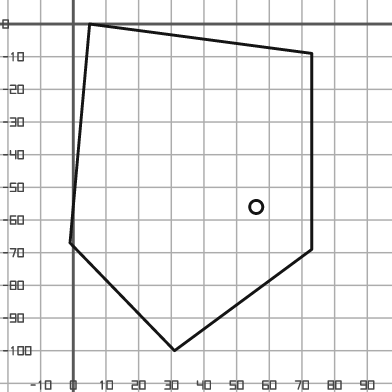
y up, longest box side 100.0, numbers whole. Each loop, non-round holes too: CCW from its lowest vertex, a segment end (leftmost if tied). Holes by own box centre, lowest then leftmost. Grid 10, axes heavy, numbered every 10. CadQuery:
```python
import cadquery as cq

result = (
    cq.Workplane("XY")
    .moveTo(31.0, -100.0)
    .lineTo(73.0, -69.0)
    .lineTo(73.0, -9.0)
    .lineTo(5.0, 0.0)
    .lineTo(-1.0, -67.0)
    .close()
    .moveTo(56.0, -56.0)
    .circle(2.0)
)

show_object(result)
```